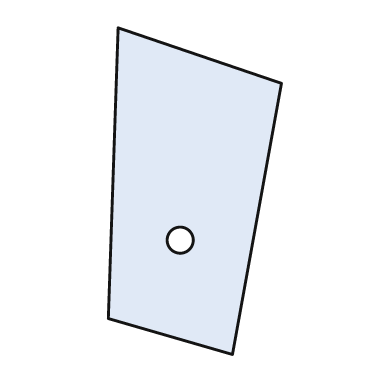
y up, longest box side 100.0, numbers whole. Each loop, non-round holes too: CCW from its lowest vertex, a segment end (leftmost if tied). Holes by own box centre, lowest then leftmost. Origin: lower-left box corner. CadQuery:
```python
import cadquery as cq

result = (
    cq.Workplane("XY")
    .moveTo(38.0, 0.0)
    .lineTo(53.0, 83.0)
    .lineTo(3.0, 100.0)
    .lineTo(0.0, 11.0)
    .close()
    .moveTo(22.0, 35.0)
    .circle(4.0)
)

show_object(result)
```